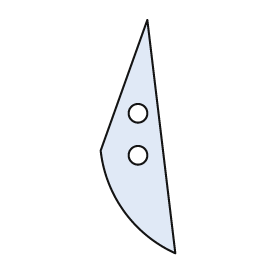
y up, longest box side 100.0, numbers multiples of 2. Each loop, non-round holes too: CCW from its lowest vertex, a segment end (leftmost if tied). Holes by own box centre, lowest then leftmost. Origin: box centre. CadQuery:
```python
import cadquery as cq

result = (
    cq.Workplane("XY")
    .moveTo(16.0, -50.0)
    .lineTo(4.0, 50.0)
    .lineTo(-16.0, -6.0)
    .threePointArc((-6.0, -32.0), (16.0, -50.0))
    .close()
    .moveTo(0.0, -8.0)
    .circle(4.0)
    .moveTo(0.0, 10.0)
    .circle(4.0)
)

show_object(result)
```